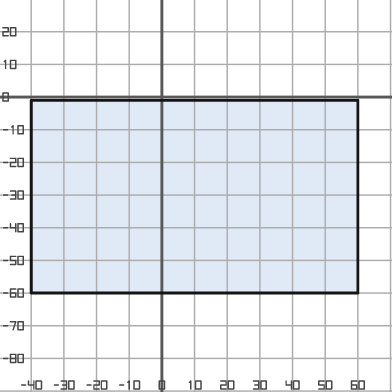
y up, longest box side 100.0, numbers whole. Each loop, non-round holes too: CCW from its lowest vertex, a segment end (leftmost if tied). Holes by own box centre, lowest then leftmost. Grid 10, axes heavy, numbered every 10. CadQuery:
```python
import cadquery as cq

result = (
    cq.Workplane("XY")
    .moveTo(-40.0, -60.0)
    .lineTo(60.0, -60.0)
    .lineTo(60.0, -1.0)
    .lineTo(-40.0, -1.0)
    .close()
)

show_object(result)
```